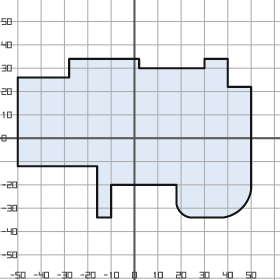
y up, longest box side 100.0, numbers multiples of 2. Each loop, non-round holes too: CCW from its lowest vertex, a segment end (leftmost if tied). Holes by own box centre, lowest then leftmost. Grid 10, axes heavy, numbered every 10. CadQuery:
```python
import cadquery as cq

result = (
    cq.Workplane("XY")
    .moveTo(-16.0, -34.0)
    .lineTo(-10.0, -34.0)
    .lineTo(-10.0, -20.0)
    .lineTo(18.0, -20.0)
    .lineTo(18.0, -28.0)
    .threePointArc((20.0, -32.0), (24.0, -34.0))
    .lineTo(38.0, -34.0)
    .threePointArc((46.0, -30.0), (50.0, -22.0))
    .lineTo(50.0, 22.0)
    .lineTo(40.0, 22.0)
    .lineTo(40.0, 34.0)
    .lineTo(30.0, 34.0)
    .lineTo(30.0, 30.0)
    .lineTo(2.0, 30.0)
    .lineTo(2.0, 34.0)
    .lineTo(-28.0, 34.0)
    .lineTo(-28.0, 26.0)
    .lineTo(-50.0, 26.0)
    .lineTo(-50.0, -12.0)
    .lineTo(-16.0, -12.0)
    .close()
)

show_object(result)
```